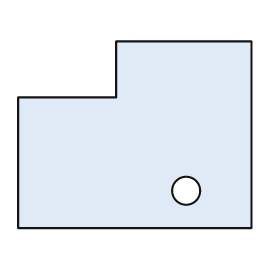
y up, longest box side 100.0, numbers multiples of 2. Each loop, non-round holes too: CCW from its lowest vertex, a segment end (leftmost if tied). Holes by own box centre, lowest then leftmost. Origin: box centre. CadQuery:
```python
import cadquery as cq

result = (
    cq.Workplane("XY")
    .moveTo(-50.0, -40.0)
    .lineTo(50.0, -40.0)
    .lineTo(50.0, 40.0)
    .lineTo(-8.0, 40.0)
    .lineTo(-8.0, 16.0)
    .lineTo(-50.0, 16.0)
    .close()
    .moveTo(22.0, -24.0)
    .circle(6.0)
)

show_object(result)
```